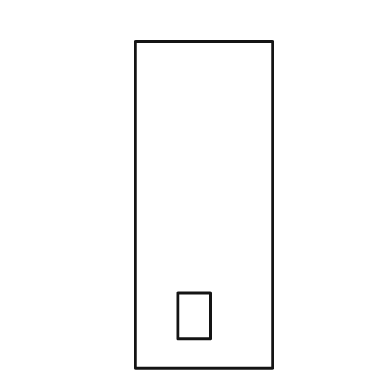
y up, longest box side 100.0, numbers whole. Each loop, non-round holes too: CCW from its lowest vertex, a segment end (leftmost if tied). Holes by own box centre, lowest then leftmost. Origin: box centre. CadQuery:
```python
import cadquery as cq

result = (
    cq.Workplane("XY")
    .moveTo(-21.0, -50.0)
    .lineTo(21.0, -50.0)
    .lineTo(21.0, 50.0)
    .lineTo(-21.0, 50.0)
    .close()
    .moveTo(-8.0, -41.0)
    .lineTo(2.0, -41.0)
    .lineTo(2.0, -27.0)
    .lineTo(-8.0, -27.0)
    .close()
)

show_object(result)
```